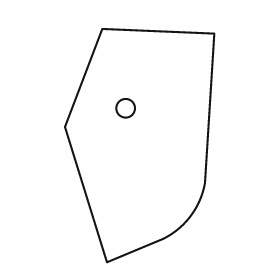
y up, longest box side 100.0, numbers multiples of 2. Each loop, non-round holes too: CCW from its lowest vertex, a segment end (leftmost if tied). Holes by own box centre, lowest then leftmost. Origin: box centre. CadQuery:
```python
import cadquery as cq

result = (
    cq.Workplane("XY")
    .moveTo(-14.0, -50.0)
    .lineTo(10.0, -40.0)
    .threePointArc((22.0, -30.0), (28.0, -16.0))
    .lineTo(32.0, 48.0)
    .lineTo(-16.0, 50.0)
    .lineTo(-32.0, 8.0)
    .close()
    .moveTo(-6.0, 16.0)
    .circle(4.0)
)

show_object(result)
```